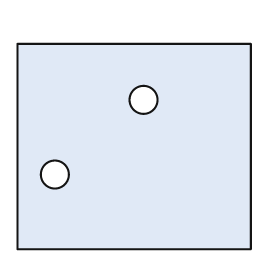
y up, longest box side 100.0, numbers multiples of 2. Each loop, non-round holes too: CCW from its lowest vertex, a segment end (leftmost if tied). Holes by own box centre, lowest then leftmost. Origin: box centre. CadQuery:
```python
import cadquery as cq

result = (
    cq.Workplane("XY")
    .moveTo(-50.0, -44.0)
    .lineTo(50.0, -44.0)
    .lineTo(50.0, 44.0)
    .lineTo(-50.0, 44.0)
    .close()
    .moveTo(-34.0, -12.0)
    .circle(6.0)
    .moveTo(4.0, 20.0)
    .circle(6.0)
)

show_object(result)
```